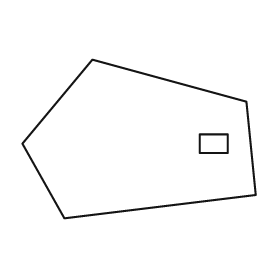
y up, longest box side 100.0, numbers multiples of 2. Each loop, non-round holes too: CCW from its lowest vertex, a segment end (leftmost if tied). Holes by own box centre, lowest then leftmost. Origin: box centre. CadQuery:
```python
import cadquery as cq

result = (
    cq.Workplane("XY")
    .moveTo(-32.0, -34.0)
    .lineTo(50.0, -24.0)
    .lineTo(46.0, 16.0)
    .lineTo(-20.0, 34.0)
    .lineTo(-50.0, -2.0)
    .close()
    .moveTo(26.0, -6.0)
    .lineTo(38.0, -6.0)
    .lineTo(38.0, 2.0)
    .lineTo(26.0, 2.0)
    .close()
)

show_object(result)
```